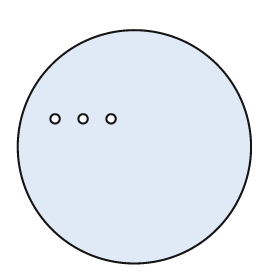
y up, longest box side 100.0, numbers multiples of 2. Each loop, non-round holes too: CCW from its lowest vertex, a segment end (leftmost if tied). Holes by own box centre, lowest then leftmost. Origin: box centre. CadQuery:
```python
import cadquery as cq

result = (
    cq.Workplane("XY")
    .moveTo(0.0, 0.0)
    .circle(50.0)
    .moveTo(-34.0, 12.0)
    .circle(2.0)
    .moveTo(-22.0, 12.0)
    .circle(2.0)
    .moveTo(-10.0, 12.0)
    .circle(2.0)
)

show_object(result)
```